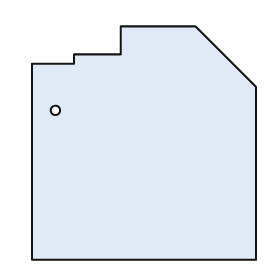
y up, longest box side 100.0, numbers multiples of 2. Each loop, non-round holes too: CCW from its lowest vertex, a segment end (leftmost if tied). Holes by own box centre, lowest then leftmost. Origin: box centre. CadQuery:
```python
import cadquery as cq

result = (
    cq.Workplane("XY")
    .moveTo(-48.0, -50.0)
    .lineTo(48.0, -50.0)
    .lineTo(48.0, 24.0)
    .lineTo(22.0, 50.0)
    .lineTo(-10.0, 50.0)
    .lineTo(-10.0, 38.0)
    .lineTo(-30.0, 38.0)
    .lineTo(-30.0, 34.0)
    .lineTo(-48.0, 34.0)
    .close()
    .moveTo(-38.0, 14.0)
    .circle(2.0)
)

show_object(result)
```